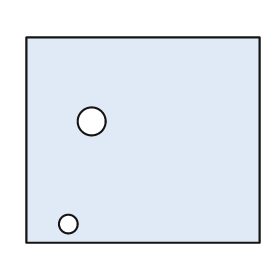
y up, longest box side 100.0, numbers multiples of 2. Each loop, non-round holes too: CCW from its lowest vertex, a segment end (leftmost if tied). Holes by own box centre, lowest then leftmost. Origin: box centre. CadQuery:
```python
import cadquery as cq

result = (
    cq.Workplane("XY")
    .moveTo(-50.0, -44.0)
    .lineTo(50.0, -44.0)
    .lineTo(50.0, 44.0)
    .lineTo(-50.0, 44.0)
    .close()
    .moveTo(-32.0, -36.0)
    .circle(4.0)
    .moveTo(-22.0, 8.0)
    .circle(6.0)
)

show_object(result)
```